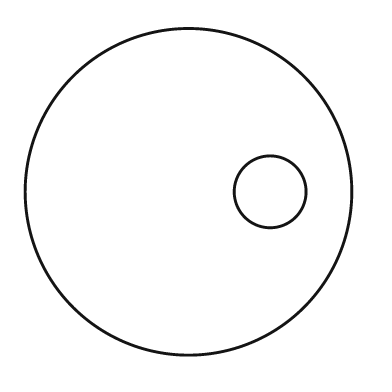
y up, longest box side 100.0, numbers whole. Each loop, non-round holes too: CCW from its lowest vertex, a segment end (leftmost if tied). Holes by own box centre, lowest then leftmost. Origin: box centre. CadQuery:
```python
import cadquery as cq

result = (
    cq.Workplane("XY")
    .moveTo(0.0, 0.0)
    .circle(50.0)
    .moveTo(25.0, 0.0)
    .circle(11.0)
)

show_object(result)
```